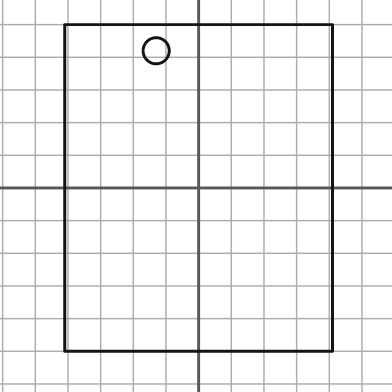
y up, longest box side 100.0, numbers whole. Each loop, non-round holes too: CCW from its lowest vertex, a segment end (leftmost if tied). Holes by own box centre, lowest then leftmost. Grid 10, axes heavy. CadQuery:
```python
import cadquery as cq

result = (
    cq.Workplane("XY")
    .moveTo(-41.0, -50.0)
    .lineTo(41.0, -50.0)
    .lineTo(41.0, 50.0)
    .lineTo(-41.0, 50.0)
    .close()
    .moveTo(-13.0, 42.0)
    .circle(4.0)
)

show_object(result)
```